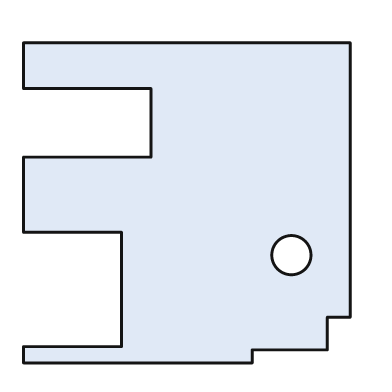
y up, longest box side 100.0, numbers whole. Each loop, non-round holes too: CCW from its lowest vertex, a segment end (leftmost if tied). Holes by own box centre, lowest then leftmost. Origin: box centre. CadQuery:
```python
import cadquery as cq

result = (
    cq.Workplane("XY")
    .moveTo(-50.0, -49.0)
    .lineTo(20.0, -49.0)
    .lineTo(20.0, -45.0)
    .lineTo(43.0, -45.0)
    .lineTo(43.0, -35.0)
    .lineTo(50.0, -35.0)
    .lineTo(50.0, 49.0)
    .lineTo(-50.0, 49.0)
    .lineTo(-50.0, 35.0)
    .lineTo(-11.0, 35.0)
    .lineTo(-11.0, 14.0)
    .lineTo(-50.0, 14.0)
    .lineTo(-50.0, -9.0)
    .lineTo(-20.0, -9.0)
    .lineTo(-20.0, -44.0)
    .lineTo(-50.0, -44.0)
    .close()
    .moveTo(32.0, -16.0)
    .circle(6.0)
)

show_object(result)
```